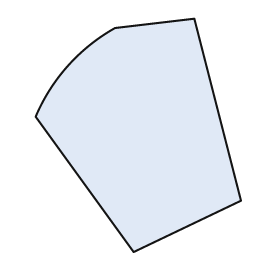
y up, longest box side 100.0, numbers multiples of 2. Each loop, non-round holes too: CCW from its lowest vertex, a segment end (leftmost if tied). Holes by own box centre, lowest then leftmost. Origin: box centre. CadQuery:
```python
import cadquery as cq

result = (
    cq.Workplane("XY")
    .moveTo(-2.0, -50.0)
    .lineTo(44.0, -28.0)
    .lineTo(24.0, 50.0)
    .lineTo(-10.0, 46.0)
    .threePointArc((-30.0, 30.0), (-44.0, 8.0))
    .close()
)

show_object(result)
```